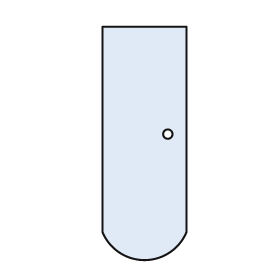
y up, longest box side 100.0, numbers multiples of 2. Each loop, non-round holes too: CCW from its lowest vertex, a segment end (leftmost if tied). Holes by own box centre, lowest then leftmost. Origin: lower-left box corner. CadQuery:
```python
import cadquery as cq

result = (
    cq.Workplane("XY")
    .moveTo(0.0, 12.0)
    .threePointArc((18.0, 0.0), (36.0, 12.0))
    .lineTo(36.0, 100.0)
    .lineTo(0.0, 100.0)
    .close()
    .moveTo(28.0, 54.0)
    .circle(2.0)
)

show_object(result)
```